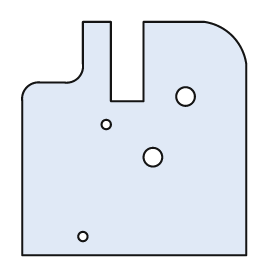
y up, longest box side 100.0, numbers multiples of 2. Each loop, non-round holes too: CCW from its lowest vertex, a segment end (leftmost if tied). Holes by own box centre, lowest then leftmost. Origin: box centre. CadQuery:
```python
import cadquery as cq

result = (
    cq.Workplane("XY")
    .moveTo(-48.0, -50.0)
    .lineTo(48.0, -50.0)
    .lineTo(48.0, 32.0)
    .threePointArc((42.0, 44.0), (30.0, 50.0))
    .lineTo(4.0, 50.0)
    .lineTo(4.0, 16.0)
    .lineTo(-10.0, 16.0)
    .lineTo(-10.0, 50.0)
    .lineTo(-22.0, 50.0)
    .lineTo(-22.0, 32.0)
    .threePointArc((-24.0, 26.0), (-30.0, 24.0))
    .lineTo(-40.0, 24.0)
    .threePointArc((-46.0, 22.0), (-48.0, 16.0))
    .close()
    .moveTo(-22.0, -42.0)
    .circle(2.0)
    .moveTo(8.0, -8.0)
    .circle(4.0)
    .moveTo(-12.0, 6.0)
    .circle(2.0)
    .moveTo(22.0, 18.0)
    .circle(4.0)
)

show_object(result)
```